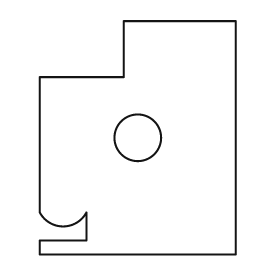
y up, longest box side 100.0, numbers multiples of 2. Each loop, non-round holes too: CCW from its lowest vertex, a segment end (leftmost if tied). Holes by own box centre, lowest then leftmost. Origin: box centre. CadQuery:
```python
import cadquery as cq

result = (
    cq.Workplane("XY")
    .moveTo(-42.0, -50.0)
    .lineTo(42.0, -50.0)
    .lineTo(42.0, 50.0)
    .lineTo(-6.0, 50.0)
    .lineTo(-6.0, 26.0)
    .lineTo(-42.0, 26.0)
    .lineTo(-42.0, -32.0)
    .threePointArc((-32.0, -38.0), (-22.0, -32.0))
    .lineTo(-22.0, -44.0)
    .lineTo(-42.0, -44.0)
    .close()
    .moveTo(0.0, 0.0)
    .circle(10.0)
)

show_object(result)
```